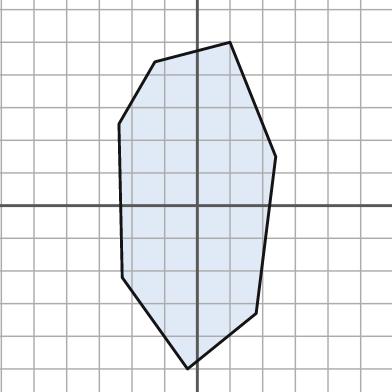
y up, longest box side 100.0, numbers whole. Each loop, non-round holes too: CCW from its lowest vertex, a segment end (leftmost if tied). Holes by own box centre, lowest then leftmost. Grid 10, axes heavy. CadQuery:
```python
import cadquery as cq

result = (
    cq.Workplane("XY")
    .moveTo(-3.0, -50.0)
    .lineTo(18.0, -33.0)
    .lineTo(24.0, 15.0)
    .lineTo(10.0, 50.0)
    .lineTo(-13.0, 44.0)
    .lineTo(-24.0, 25.0)
    .lineTo(-23.0, -22.0)
    .close()
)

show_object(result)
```